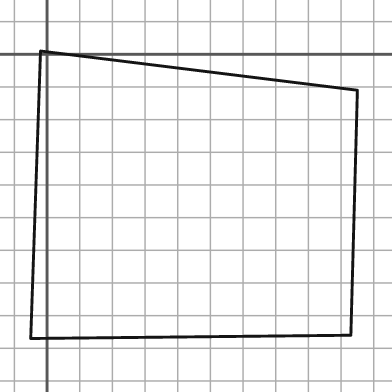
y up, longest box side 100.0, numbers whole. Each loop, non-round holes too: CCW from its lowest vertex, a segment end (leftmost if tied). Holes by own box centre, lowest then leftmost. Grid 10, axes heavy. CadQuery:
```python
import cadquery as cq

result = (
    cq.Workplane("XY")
    .moveTo(-5.0, -87.0)
    .lineTo(93.0, -86.0)
    .lineTo(95.0, -11.0)
    .lineTo(-2.0, 1.0)
    .close()
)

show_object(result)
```